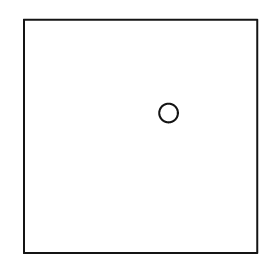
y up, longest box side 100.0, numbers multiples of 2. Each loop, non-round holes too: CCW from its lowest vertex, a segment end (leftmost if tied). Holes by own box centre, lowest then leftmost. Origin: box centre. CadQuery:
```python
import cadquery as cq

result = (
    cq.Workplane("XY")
    .moveTo(-50.0, -50.0)
    .lineTo(50.0, -50.0)
    .lineTo(50.0, 50.0)
    .lineTo(-50.0, 50.0)
    .close()
    .moveTo(12.0, 10.0)
    .circle(4.0)
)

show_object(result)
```